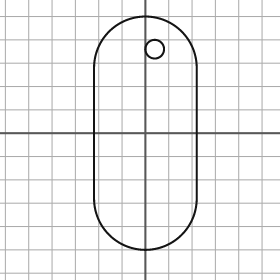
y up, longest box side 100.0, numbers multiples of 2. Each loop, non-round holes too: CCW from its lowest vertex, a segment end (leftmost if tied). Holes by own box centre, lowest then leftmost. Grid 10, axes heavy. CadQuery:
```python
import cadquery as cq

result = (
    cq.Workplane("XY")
    .moveTo(-22.0, -28.0)
    .threePointArc((0.0, -50.0), (22.0, -28.0))
    .lineTo(22.0, 28.0)
    .threePointArc((0.0, 50.0), (-22.0, 28.0))
    .close()
    .moveTo(4.0, 36.0)
    .circle(4.0)
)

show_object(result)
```